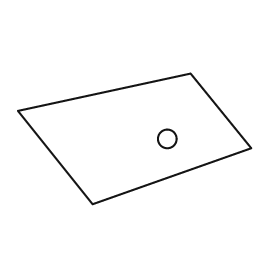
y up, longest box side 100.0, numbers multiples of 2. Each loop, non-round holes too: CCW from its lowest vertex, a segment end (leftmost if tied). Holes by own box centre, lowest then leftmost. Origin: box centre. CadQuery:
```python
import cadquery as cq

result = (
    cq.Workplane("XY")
    .moveTo(-18.0, -28.0)
    .lineTo(50.0, -4.0)
    .lineTo(24.0, 28.0)
    .lineTo(-50.0, 12.0)
    .close()
    .moveTo(14.0, 0.0)
    .circle(4.0)
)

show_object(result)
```